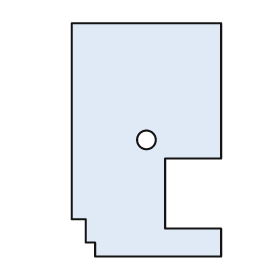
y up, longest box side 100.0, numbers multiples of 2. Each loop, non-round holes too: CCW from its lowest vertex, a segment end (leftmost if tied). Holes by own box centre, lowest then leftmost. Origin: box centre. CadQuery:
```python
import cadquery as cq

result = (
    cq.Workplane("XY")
    .moveTo(-22.0, -50.0)
    .lineTo(32.0, -50.0)
    .lineTo(32.0, -38.0)
    .lineTo(8.0, -38.0)
    .lineTo(8.0, -8.0)
    .lineTo(32.0, -8.0)
    .lineTo(32.0, 50.0)
    .lineTo(-32.0, 50.0)
    .lineTo(-32.0, -34.0)
    .lineTo(-26.0, -34.0)
    .lineTo(-26.0, -44.0)
    .lineTo(-22.0, -44.0)
    .close()
    .moveTo(0.0, 0.0)
    .circle(4.0)
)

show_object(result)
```